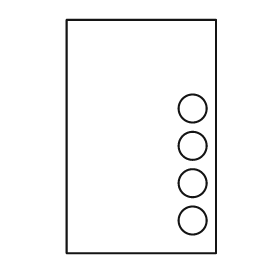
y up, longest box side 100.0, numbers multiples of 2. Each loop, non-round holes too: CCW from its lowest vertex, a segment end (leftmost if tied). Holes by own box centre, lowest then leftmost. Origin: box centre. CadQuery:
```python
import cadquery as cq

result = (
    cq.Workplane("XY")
    .moveTo(-32.0, -50.0)
    .lineTo(32.0, -50.0)
    .lineTo(32.0, 50.0)
    .lineTo(-32.0, 50.0)
    .close()
    .moveTo(22.0, -36.0)
    .circle(6.0)
    .moveTo(22.0, -20.0)
    .circle(6.0)
    .moveTo(22.0, -4.0)
    .circle(6.0)
    .moveTo(22.0, 12.0)
    .circle(6.0)
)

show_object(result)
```